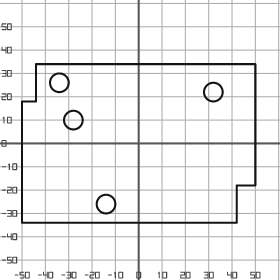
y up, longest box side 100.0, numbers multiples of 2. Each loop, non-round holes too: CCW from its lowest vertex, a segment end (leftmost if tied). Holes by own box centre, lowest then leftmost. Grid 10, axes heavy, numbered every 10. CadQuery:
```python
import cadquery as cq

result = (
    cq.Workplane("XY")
    .moveTo(-50.0, -34.0)
    .lineTo(42.0, -34.0)
    .lineTo(42.0, -18.0)
    .lineTo(50.0, -18.0)
    .lineTo(50.0, 34.0)
    .lineTo(-44.0, 34.0)
    .lineTo(-44.0, 18.0)
    .lineTo(-50.0, 18.0)
    .close()
    .moveTo(-14.0, -26.0)
    .circle(4.0)
    .moveTo(-28.0, 10.0)
    .circle(4.0)
    .moveTo(32.0, 22.0)
    .circle(4.0)
    .moveTo(-34.0, 26.0)
    .circle(4.0)
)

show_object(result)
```